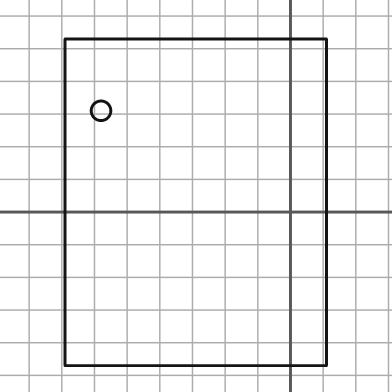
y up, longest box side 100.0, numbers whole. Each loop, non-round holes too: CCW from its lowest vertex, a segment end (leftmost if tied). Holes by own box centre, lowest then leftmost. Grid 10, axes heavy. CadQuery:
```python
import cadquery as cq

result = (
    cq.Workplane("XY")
    .moveTo(-69.0, -47.0)
    .lineTo(11.0, -47.0)
    .lineTo(11.0, 53.0)
    .lineTo(-69.0, 53.0)
    .close()
    .moveTo(-58.0, 31.0)
    .circle(3.0)
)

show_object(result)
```